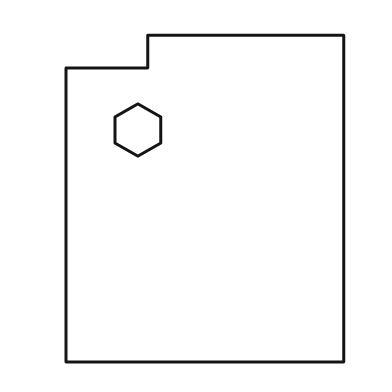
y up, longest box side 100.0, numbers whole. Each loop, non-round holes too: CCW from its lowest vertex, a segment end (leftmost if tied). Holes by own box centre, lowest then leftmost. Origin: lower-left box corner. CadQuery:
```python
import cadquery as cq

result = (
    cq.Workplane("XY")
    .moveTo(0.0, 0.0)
    .lineTo(85.0, 0.0)
    .lineTo(85.0, 100.0)
    .lineTo(25.0, 100.0)
    .lineTo(25.0, 90.0)
    .lineTo(0.0, 90.0)
    .close()
    .moveTo(22.0, 63.0)
    .lineTo(29.0, 67.0)
    .lineTo(29.0, 75.0)
    .lineTo(22.0, 79.0)
    .lineTo(15.0, 75.0)
    .lineTo(15.0, 67.0)
    .close()
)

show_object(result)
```